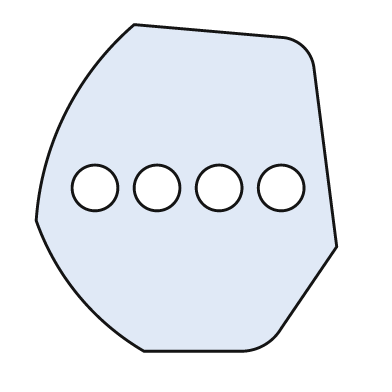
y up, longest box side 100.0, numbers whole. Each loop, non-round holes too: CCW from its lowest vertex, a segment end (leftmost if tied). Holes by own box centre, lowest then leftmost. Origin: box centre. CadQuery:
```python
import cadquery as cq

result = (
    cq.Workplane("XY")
    .moveTo(-13.0, -50.0)
    .lineTo(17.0, -50.0)
    .threePointArc((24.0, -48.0), (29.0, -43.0))
    .lineTo(46.0, -18.0)
    .lineTo(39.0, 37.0)
    .threePointArc((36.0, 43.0), (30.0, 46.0))
    .lineTo(-16.0, 50.0)
    .threePointArc((-37.0, 23.0), (-46.0, -10.0))
    .threePointArc((-33.0, -33.0), (-13.0, -50.0))
    .close()
    .moveTo(-28.0, 0.0)
    .circle(7.0)
    .moveTo(-9.0, 0.0)
    .circle(7.0)
    .moveTo(10.0, 0.0)
    .circle(7.0)
    .moveTo(29.0, 0.0)
    .circle(7.0)
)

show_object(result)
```